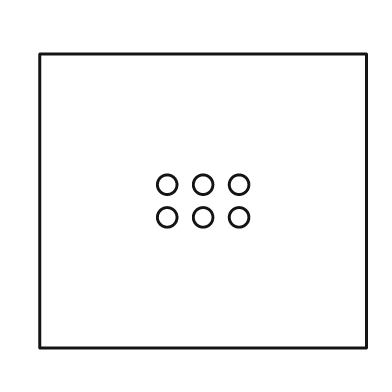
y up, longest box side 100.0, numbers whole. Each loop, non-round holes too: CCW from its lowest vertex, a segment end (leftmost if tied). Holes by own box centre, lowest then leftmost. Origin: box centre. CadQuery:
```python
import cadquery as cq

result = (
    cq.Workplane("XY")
    .moveTo(-50.0, -45.0)
    .lineTo(50.0, -45.0)
    .lineTo(50.0, 45.0)
    .lineTo(-50.0, 45.0)
    .close()
    .moveTo(-11.0, -5.0)
    .circle(3.0)
    .moveTo(0.0, -5.0)
    .circle(3.0)
    .moveTo(11.0, -5.0)
    .circle(3.0)
    .moveTo(-11.0, 5.0)
    .circle(3.0)
    .moveTo(0.0, 5.0)
    .circle(3.0)
    .moveTo(11.0, 5.0)
    .circle(3.0)
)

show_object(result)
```